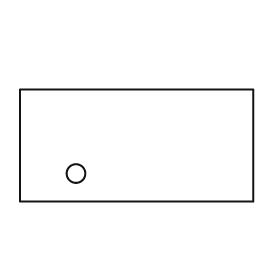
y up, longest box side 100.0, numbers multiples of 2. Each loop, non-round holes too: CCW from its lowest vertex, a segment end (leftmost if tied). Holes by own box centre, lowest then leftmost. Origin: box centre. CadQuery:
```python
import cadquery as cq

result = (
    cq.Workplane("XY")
    .moveTo(-50.0, -24.0)
    .lineTo(50.0, -24.0)
    .lineTo(50.0, 24.0)
    .lineTo(-50.0, 24.0)
    .close()
    .moveTo(-26.0, -12.0)
    .circle(4.0)
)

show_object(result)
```